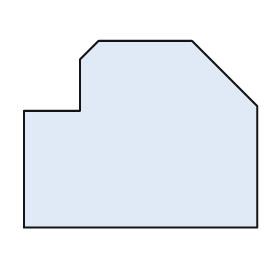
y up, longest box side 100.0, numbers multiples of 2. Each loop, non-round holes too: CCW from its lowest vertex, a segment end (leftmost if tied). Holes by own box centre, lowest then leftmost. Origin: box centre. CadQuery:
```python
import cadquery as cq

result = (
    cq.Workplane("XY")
    .moveTo(-50.0, -40.0)
    .lineTo(50.0, -40.0)
    .lineTo(50.0, 12.0)
    .lineTo(22.0, 40.0)
    .lineTo(-18.0, 40.0)
    .lineTo(-26.0, 32.0)
    .lineTo(-26.0, 10.0)
    .lineTo(-50.0, 10.0)
    .close()
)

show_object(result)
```